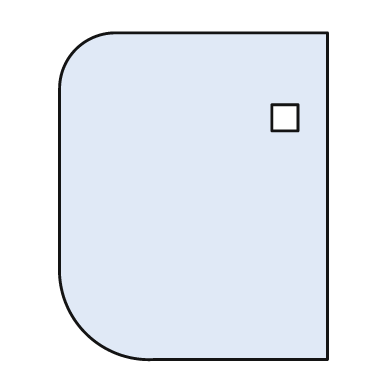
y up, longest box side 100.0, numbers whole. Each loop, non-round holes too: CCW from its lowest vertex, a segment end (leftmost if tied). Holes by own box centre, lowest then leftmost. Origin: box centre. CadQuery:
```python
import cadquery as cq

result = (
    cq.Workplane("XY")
    .moveTo(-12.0, -50.0)
    .lineTo(41.0, -50.0)
    .lineTo(41.0, 50.0)
    .lineTo(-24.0, 50.0)
    .threePointArc((-36.0, 45.0), (-41.0, 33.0))
    .lineTo(-41.0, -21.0)
    .threePointArc((-33.0, -42.0), (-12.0, -50.0))
    .close()
    .moveTo(24.0, 20.0)
    .lineTo(32.0, 20.0)
    .lineTo(32.0, 28.0)
    .lineTo(24.0, 28.0)
    .close()
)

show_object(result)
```